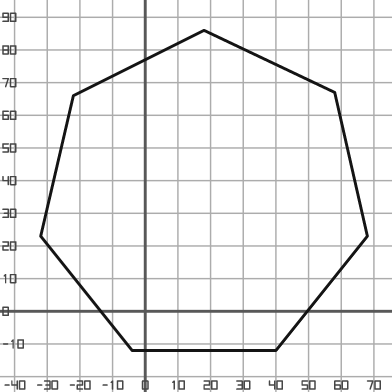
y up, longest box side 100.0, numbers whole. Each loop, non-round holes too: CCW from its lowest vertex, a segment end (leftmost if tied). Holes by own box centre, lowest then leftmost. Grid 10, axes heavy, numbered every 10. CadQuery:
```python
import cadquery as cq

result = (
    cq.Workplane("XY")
    .moveTo(-4.0, -12.0)
    .lineTo(40.0, -12.0)
    .lineTo(68.0, 23.0)
    .lineTo(58.0, 67.0)
    .lineTo(18.0, 86.0)
    .lineTo(-22.0, 66.0)
    .lineTo(-32.0, 23.0)
    .close()
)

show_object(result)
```